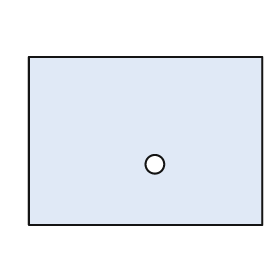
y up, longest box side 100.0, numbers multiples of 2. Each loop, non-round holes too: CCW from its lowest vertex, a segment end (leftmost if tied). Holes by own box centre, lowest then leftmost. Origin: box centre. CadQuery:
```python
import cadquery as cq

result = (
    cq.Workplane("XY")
    .moveTo(-50.0, -36.0)
    .lineTo(50.0, -36.0)
    .lineTo(50.0, 36.0)
    .lineTo(-50.0, 36.0)
    .close()
    .moveTo(4.0, -10.0)
    .circle(4.0)
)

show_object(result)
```